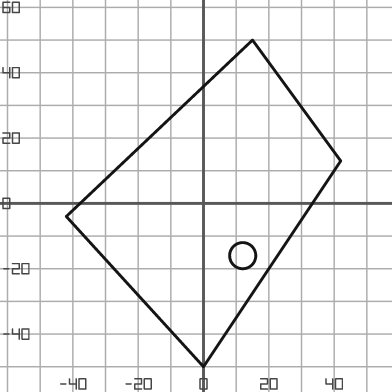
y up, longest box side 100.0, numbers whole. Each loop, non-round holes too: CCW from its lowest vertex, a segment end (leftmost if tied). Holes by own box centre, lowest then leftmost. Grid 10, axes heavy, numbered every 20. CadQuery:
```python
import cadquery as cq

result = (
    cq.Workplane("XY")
    .moveTo(0.0, -50.0)
    .lineTo(42.0, 13.0)
    .lineTo(15.0, 50.0)
    .lineTo(-42.0, -4.0)
    .close()
    .moveTo(12.0, -16.0)
    .circle(4.0)
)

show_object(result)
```